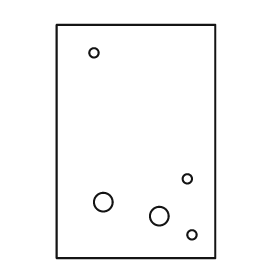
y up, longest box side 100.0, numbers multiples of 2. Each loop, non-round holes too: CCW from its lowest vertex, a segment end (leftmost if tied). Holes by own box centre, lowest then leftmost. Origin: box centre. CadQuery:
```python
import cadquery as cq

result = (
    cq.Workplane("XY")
    .moveTo(-34.0, -50.0)
    .lineTo(34.0, -50.0)
    .lineTo(34.0, 50.0)
    .lineTo(-34.0, 50.0)
    .close()
    .moveTo(24.0, -40.0)
    .circle(2.0)
    .moveTo(10.0, -32.0)
    .circle(4.0)
    .moveTo(-14.0, -26.0)
    .circle(4.0)
    .moveTo(22.0, -16.0)
    .circle(2.0)
    .moveTo(-18.0, 38.0)
    .circle(2.0)
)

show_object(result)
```